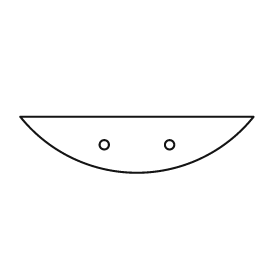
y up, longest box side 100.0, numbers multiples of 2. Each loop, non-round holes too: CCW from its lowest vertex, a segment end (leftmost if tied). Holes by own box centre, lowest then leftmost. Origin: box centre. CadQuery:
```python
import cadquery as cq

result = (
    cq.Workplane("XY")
    .moveTo(-50.0, 12.0)
    .threePointArc((0.0, -12.0), (50.0, 12.0))
    .close()
    .moveTo(-14.0, 0.0)
    .circle(2.0)
    .moveTo(14.0, 0.0)
    .circle(2.0)
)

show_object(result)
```